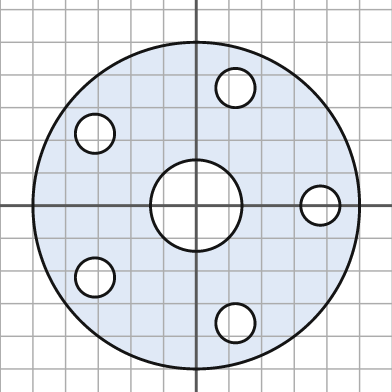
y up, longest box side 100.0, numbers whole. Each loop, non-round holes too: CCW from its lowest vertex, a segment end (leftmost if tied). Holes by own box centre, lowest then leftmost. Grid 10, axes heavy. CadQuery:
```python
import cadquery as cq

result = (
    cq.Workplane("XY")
    .moveTo(0.0, 0.0)
    .circle(50.0)
    .moveTo(12.0, -36.0)
    .circle(6.0)
    .moveTo(-31.0, -22.0)
    .circle(6.0)
    .moveTo(0.0, 0.0)
    .circle(14.0)
    .moveTo(38.0, 0.0)
    .circle(6.0)
    .moveTo(-31.0, 22.0)
    .circle(6.0)
    .moveTo(12.0, 36.0)
    .circle(6.0)
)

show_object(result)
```